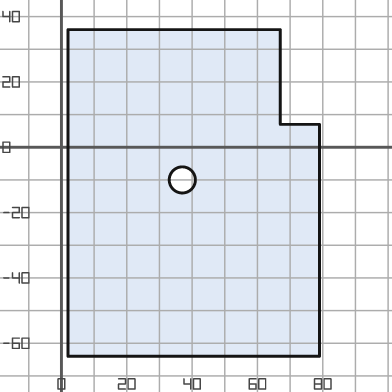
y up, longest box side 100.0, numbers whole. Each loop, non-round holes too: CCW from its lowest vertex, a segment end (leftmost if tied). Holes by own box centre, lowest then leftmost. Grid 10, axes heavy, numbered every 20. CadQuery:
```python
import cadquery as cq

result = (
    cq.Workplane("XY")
    .moveTo(2.0, -64.0)
    .lineTo(79.0, -64.0)
    .lineTo(79.0, 7.0)
    .lineTo(67.0, 7.0)
    .lineTo(67.0, 36.0)
    .lineTo(2.0, 36.0)
    .close()
    .moveTo(37.0, -10.0)
    .circle(4.0)
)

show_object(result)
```